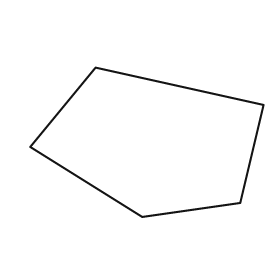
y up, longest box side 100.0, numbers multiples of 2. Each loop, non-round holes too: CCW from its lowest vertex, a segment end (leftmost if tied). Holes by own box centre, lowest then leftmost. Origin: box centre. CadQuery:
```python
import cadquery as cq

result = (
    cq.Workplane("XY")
    .moveTo(-2.0, -32.0)
    .lineTo(40.0, -26.0)
    .lineTo(50.0, 16.0)
    .lineTo(-22.0, 32.0)
    .lineTo(-50.0, -2.0)
    .close()
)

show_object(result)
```